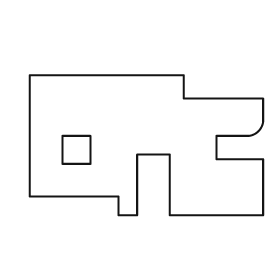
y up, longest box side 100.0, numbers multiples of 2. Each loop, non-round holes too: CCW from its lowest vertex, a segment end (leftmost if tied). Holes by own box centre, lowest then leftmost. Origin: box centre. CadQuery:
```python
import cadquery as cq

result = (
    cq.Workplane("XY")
    .moveTo(-12.0, -30.0)
    .lineTo(-4.0, -30.0)
    .lineTo(-4.0, -4.0)
    .lineTo(10.0, -4.0)
    .lineTo(10.0, -30.0)
    .lineTo(50.0, -30.0)
    .lineTo(50.0, -6.0)
    .lineTo(30.0, -6.0)
    .lineTo(30.0, 4.0)
    .lineTo(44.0, 4.0)
    .threePointArc((48.0, 6.0), (50.0, 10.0))
    .lineTo(50.0, 20.0)
    .lineTo(16.0, 20.0)
    .lineTo(16.0, 30.0)
    .lineTo(-50.0, 30.0)
    .lineTo(-50.0, -22.0)
    .lineTo(-12.0, -22.0)
    .close()
    .moveTo(-36.0, -8.0)
    .lineTo(-24.0, -8.0)
    .lineTo(-24.0, 4.0)
    .lineTo(-36.0, 4.0)
    .close()
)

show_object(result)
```